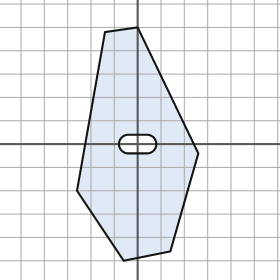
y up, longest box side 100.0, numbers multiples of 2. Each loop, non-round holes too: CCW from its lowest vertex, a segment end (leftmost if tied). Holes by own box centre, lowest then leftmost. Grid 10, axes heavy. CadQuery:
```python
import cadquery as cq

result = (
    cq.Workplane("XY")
    .moveTo(-6.0, -50.0)
    .lineTo(14.0, -46.0)
    .lineTo(26.0, -4.0)
    .lineTo(0.0, 50.0)
    .lineTo(-14.0, 48.0)
    .lineTo(-26.0, -20.0)
    .close()
    .moveTo(-4.0, -4.0)
    .lineTo(4.0, -4.0)
    .threePointArc((8.0, 0.0), (4.0, 4.0))
    .lineTo(-4.0, 4.0)
    .threePointArc((-8.0, 0.0), (-4.0, -4.0))
    .close()
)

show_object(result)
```